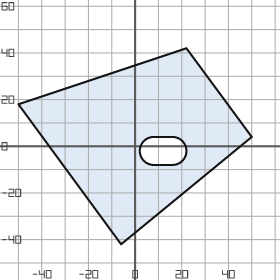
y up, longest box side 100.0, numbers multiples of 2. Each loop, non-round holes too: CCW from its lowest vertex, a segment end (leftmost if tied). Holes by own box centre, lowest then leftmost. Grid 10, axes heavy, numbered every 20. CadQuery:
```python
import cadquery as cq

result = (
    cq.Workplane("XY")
    .moveTo(-6.0, -42.0)
    .lineTo(50.0, 4.0)
    .lineTo(22.0, 42.0)
    .lineTo(-50.0, 18.0)
    .close()
    .moveTo(8.0, -8.0)
    .lineTo(16.0, -8.0)
    .threePointArc((22.0, -2.0), (16.0, 4.0))
    .lineTo(8.0, 4.0)
    .threePointArc((2.0, -2.0), (8.0, -8.0))
    .close()
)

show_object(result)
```